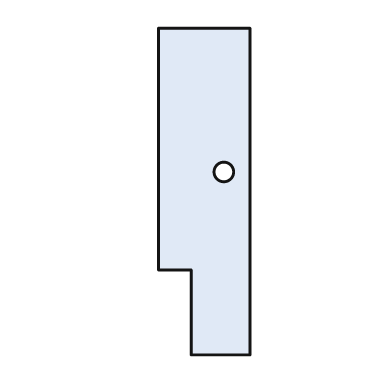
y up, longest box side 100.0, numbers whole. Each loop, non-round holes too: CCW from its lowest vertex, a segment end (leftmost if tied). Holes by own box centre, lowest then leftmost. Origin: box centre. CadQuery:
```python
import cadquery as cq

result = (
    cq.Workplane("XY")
    .moveTo(-4.0, -50.0)
    .lineTo(14.0, -50.0)
    .lineTo(14.0, 50.0)
    .lineTo(-14.0, 50.0)
    .lineTo(-14.0, -24.0)
    .lineTo(-4.0, -24.0)
    .close()
    .moveTo(6.0, 6.0)
    .circle(3.0)
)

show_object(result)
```